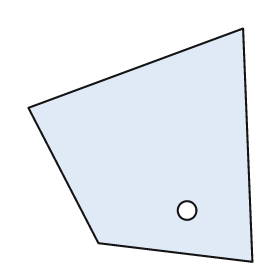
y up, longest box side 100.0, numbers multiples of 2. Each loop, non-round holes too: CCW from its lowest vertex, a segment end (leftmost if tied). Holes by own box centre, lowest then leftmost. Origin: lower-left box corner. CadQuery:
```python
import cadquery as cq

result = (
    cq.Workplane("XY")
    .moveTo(96.0, 0.0)
    .lineTo(92.0, 100.0)
    .lineTo(0.0, 66.0)
    .lineTo(30.0, 8.0)
    .close()
    .moveTo(68.0, 22.0)
    .circle(4.0)
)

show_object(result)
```